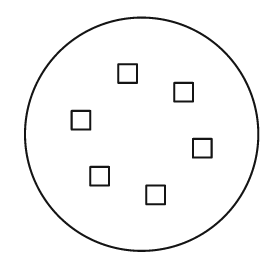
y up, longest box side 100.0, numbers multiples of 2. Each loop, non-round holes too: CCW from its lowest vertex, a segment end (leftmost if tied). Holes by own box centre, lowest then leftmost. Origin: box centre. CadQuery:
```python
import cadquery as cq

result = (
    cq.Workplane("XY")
    .moveTo(0.0, 0.0)
    .circle(50.0)
    .moveTo(2.0, -30.0)
    .lineTo(10.0, -30.0)
    .lineTo(10.0, -22.0)
    .lineTo(2.0, -22.0)
    .close()
    .moveTo(-22.0, -22.0)
    .lineTo(-14.0, -22.0)
    .lineTo(-14.0, -14.0)
    .lineTo(-22.0, -14.0)
    .close()
    .moveTo(22.0, -10.0)
    .lineTo(30.0, -10.0)
    .lineTo(30.0, -2.0)
    .lineTo(22.0, -2.0)
    .close()
    .moveTo(-30.0, 2.0)
    .lineTo(-22.0, 2.0)
    .lineTo(-22.0, 10.0)
    .lineTo(-30.0, 10.0)
    .close()
    .moveTo(14.0, 14.0)
    .lineTo(22.0, 14.0)
    .lineTo(22.0, 22.0)
    .lineTo(14.0, 22.0)
    .close()
    .moveTo(-10.0, 22.0)
    .lineTo(-2.0, 22.0)
    .lineTo(-2.0, 30.0)
    .lineTo(-10.0, 30.0)
    .close()
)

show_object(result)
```